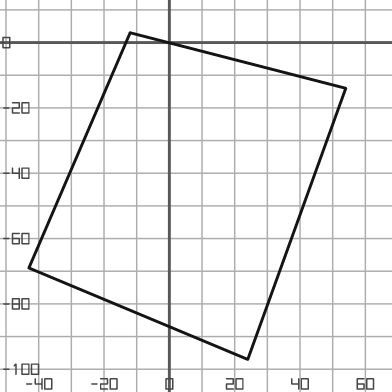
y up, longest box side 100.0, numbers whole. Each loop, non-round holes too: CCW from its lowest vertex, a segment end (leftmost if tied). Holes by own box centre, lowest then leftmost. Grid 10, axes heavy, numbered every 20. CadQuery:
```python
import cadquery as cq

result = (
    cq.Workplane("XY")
    .moveTo(24.0, -97.0)
    .lineTo(54.0, -14.0)
    .lineTo(-12.0, 3.0)
    .lineTo(-43.0, -69.0)
    .close()
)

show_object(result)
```